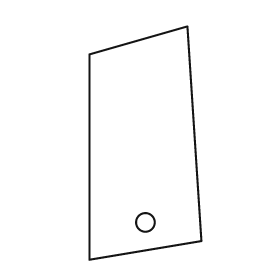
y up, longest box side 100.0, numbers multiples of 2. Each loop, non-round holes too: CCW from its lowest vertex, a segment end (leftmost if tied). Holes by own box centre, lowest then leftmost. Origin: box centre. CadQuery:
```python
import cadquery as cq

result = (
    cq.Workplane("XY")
    .moveTo(-24.0, -50.0)
    .lineTo(24.0, -42.0)
    .lineTo(18.0, 50.0)
    .lineTo(-24.0, 38.0)
    .close()
    .moveTo(0.0, -34.0)
    .circle(4.0)
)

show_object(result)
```